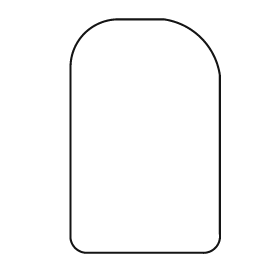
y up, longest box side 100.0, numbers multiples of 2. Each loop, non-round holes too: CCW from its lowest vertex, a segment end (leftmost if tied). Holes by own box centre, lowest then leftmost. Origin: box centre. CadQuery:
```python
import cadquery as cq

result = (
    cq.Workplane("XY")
    .moveTo(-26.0, -50.0)
    .lineTo(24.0, -50.0)
    .threePointArc((30.0, -48.0), (32.0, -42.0))
    .lineTo(32.0, 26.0)
    .threePointArc((24.0, 42.0), (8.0, 50.0))
    .lineTo(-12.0, 50.0)
    .threePointArc((-26.0, 44.0), (-32.0, 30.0))
    .lineTo(-32.0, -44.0)
    .threePointArc((-30.0, -48.0), (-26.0, -50.0))
    .close()
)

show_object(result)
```